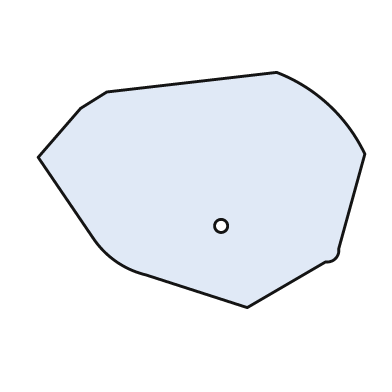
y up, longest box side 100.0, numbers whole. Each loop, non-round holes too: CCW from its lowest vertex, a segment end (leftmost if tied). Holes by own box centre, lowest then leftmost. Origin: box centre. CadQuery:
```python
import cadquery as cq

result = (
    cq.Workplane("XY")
    .moveTo(14.0, -36.0)
    .lineTo(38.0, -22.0)
    .threePointArc((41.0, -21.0), (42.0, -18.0))
    .lineTo(50.0, 11.0)
    .threePointArc((39.0, 26.0), (23.0, 36.0))
    .lineTo(-29.0, 30.0)
    .lineTo(-37.0, 25.0)
    .lineTo(-50.0, 10.0)
    .lineTo(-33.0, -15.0)
    .threePointArc((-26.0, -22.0), (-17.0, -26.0))
    .close()
    .moveTo(6.0, -11.0)
    .circle(2.0)
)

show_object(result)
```